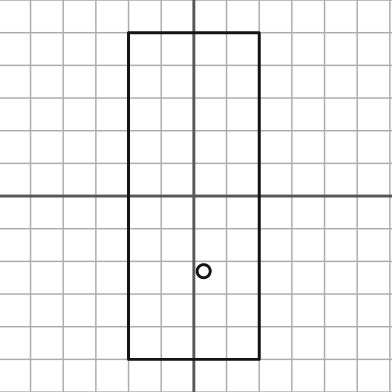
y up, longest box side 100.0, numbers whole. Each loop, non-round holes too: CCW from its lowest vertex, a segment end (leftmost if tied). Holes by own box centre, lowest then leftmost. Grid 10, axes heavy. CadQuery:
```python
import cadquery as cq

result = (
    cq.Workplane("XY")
    .moveTo(-20.0, -50.0)
    .lineTo(20.0, -50.0)
    .lineTo(20.0, 50.0)
    .lineTo(-20.0, 50.0)
    .close()
    .moveTo(3.0, -23.0)
    .circle(2.0)
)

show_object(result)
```